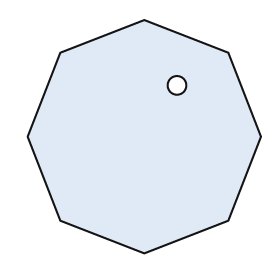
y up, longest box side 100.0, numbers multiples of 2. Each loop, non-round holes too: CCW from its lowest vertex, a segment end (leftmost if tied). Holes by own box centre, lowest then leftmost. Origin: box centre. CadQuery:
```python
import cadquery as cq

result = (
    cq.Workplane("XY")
    .moveTo(0.0, -50.0)
    .lineTo(36.0, -36.0)
    .lineTo(50.0, 0.0)
    .lineTo(36.0, 36.0)
    .lineTo(0.0, 50.0)
    .lineTo(-36.0, 36.0)
    .lineTo(-50.0, 0.0)
    .lineTo(-36.0, -36.0)
    .close()
    .moveTo(14.0, 22.0)
    .circle(4.0)
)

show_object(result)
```